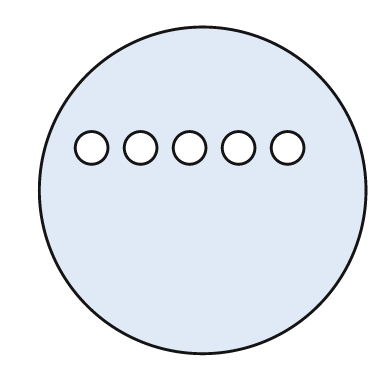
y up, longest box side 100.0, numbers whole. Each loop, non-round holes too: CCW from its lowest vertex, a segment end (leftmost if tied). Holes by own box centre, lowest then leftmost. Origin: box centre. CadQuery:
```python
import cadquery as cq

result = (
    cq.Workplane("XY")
    .moveTo(0.0, 0.0)
    .circle(50.0)
    .moveTo(-34.0, 13.0)
    .circle(5.0)
    .moveTo(-19.0, 13.0)
    .circle(5.0)
    .moveTo(-4.0, 13.0)
    .circle(5.0)
    .moveTo(11.0, 13.0)
    .circle(5.0)
    .moveTo(26.0, 13.0)
    .circle(5.0)
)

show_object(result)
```